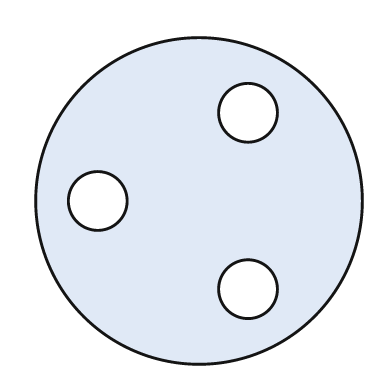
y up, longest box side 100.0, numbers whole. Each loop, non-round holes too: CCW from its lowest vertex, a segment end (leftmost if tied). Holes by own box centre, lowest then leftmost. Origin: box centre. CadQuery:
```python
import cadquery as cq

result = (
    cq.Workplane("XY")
    .moveTo(0.0, 0.0)
    .circle(50.0)
    .moveTo(15.0, -27.0)
    .circle(9.0)
    .moveTo(-31.0, 0.0)
    .circle(9.0)
    .moveTo(15.0, 27.0)
    .circle(9.0)
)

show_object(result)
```